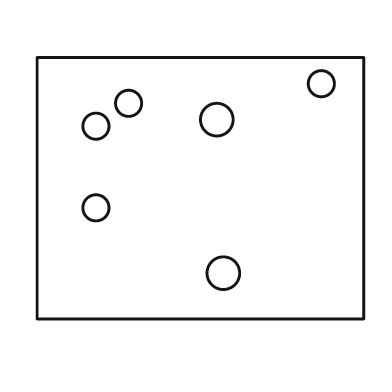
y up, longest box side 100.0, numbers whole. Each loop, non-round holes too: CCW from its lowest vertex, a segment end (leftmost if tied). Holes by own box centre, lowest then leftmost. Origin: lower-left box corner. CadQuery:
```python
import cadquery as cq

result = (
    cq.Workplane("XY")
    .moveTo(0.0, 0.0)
    .lineTo(100.0, 0.0)
    .lineTo(100.0, 80.0)
    .lineTo(0.0, 80.0)
    .close()
    .moveTo(57.0, 14.0)
    .circle(5.0)
    .moveTo(18.0, 34.0)
    .circle(4.0)
    .moveTo(18.0, 59.0)
    .circle(4.0)
    .moveTo(55.0, 61.0)
    .circle(5.0)
    .moveTo(28.0, 66.0)
    .circle(4.0)
    .moveTo(87.0, 72.0)
    .circle(4.0)
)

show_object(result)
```